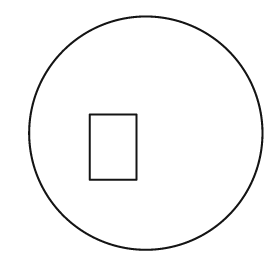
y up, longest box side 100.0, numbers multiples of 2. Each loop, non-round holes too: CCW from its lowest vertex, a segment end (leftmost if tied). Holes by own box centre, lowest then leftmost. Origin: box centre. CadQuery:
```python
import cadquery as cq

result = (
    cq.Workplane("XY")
    .moveTo(0.0, 0.0)
    .circle(50.0)
    .moveTo(-24.0, -20.0)
    .lineTo(-4.0, -20.0)
    .lineTo(-4.0, 8.0)
    .lineTo(-24.0, 8.0)
    .close()
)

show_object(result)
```